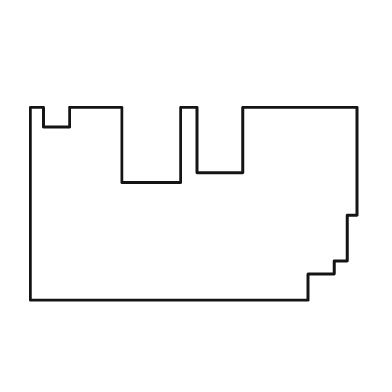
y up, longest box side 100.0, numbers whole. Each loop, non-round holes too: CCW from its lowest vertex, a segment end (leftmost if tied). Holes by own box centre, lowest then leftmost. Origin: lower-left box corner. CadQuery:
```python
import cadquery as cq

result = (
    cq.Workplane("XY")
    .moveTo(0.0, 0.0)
    .lineTo(85.0, 0.0)
    .lineTo(85.0, 8.0)
    .lineTo(93.0, 8.0)
    .lineTo(93.0, 12.0)
    .lineTo(97.0, 12.0)
    .lineTo(97.0, 26.0)
    .lineTo(100.0, 26.0)
    .lineTo(100.0, 59.0)
    .lineTo(65.0, 59.0)
    .lineTo(65.0, 39.0)
    .lineTo(51.0, 39.0)
    .lineTo(51.0, 59.0)
    .lineTo(46.0, 59.0)
    .lineTo(46.0, 36.0)
    .lineTo(28.0, 36.0)
    .lineTo(28.0, 59.0)
    .lineTo(12.0, 59.0)
    .lineTo(12.0, 53.0)
    .lineTo(4.0, 53.0)
    .lineTo(4.0, 59.0)
    .lineTo(0.0, 59.0)
    .close()
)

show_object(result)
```